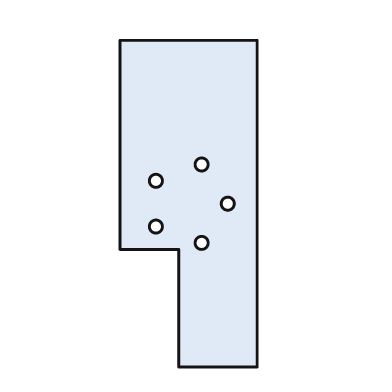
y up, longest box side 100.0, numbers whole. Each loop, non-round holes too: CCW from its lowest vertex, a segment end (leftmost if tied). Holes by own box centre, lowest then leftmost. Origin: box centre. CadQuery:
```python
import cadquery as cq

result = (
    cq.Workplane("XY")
    .moveTo(-3.0, -50.0)
    .lineTo(21.0, -50.0)
    .lineTo(21.0, 50.0)
    .lineTo(-21.0, 50.0)
    .lineTo(-21.0, -14.0)
    .lineTo(-3.0, -14.0)
    .close()
    .moveTo(4.0, -12.0)
    .circle(2.0)
    .moveTo(-10.0, -7.0)
    .circle(2.0)
    .moveTo(12.0, 0.0)
    .circle(2.0)
    .moveTo(-10.0, 7.0)
    .circle(2.0)
    .moveTo(4.0, 12.0)
    .circle(2.0)
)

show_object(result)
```